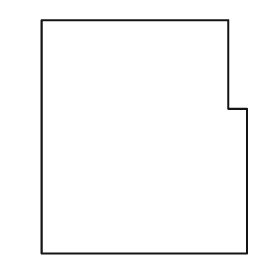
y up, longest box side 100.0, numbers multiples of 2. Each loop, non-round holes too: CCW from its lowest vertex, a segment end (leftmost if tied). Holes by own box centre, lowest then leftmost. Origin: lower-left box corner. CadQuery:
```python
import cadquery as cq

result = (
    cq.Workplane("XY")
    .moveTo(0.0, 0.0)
    .lineTo(88.0, 0.0)
    .lineTo(88.0, 62.0)
    .lineTo(80.0, 62.0)
    .lineTo(80.0, 100.0)
    .lineTo(0.0, 100.0)
    .close()
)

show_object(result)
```